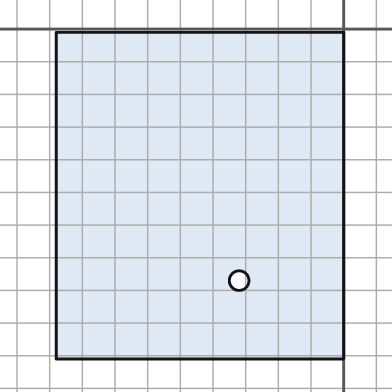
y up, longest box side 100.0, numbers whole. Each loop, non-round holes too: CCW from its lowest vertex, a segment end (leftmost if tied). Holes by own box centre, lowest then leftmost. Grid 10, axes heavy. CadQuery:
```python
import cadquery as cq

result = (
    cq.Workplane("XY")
    .moveTo(-88.0, -101.0)
    .lineTo(0.0, -101.0)
    .lineTo(0.0, -1.0)
    .lineTo(-88.0, -1.0)
    .close()
    .moveTo(-32.0, -77.0)
    .circle(3.0)
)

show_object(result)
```